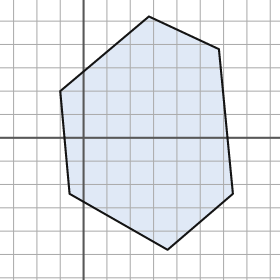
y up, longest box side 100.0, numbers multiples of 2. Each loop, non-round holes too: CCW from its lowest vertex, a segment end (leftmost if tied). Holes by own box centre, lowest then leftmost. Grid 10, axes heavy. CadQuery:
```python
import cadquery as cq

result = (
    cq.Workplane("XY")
    .moveTo(36.0, -48.0)
    .lineTo(64.0, -24.0)
    .lineTo(58.0, 38.0)
    .lineTo(28.0, 52.0)
    .lineTo(-10.0, 20.0)
    .lineTo(-6.0, -24.0)
    .close()
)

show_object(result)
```